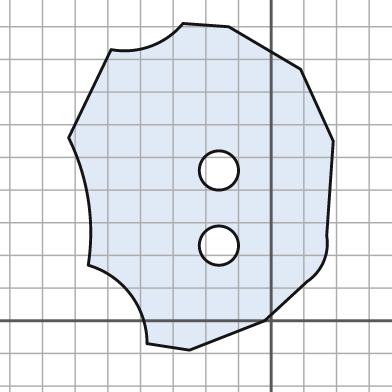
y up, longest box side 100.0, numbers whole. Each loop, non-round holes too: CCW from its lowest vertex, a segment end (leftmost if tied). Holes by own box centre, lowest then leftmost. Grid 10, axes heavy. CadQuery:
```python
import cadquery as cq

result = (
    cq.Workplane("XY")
    .moveTo(-25.0, -9.0)
    .lineTo(-2.0, 0.0)
    .lineTo(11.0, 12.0)
    .threePointArc((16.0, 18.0), (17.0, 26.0))
    .lineTo(19.0, 55.0)
    .lineTo(9.0, 77.0)
    .lineTo(-13.0, 90.0)
    .lineTo(-27.0, 91.0)
    .threePointArc((-37.0, 84.0), (-49.0, 83.0))
    .lineTo(-62.0, 56.0)
    .threePointArc((-56.0, 37.0), (-56.0, 17.0))
    .threePointArc((-43.0, 8.0), (-38.0, -7.0))
    .close()
    .moveTo(-16.0, 23.0)
    .circle(6.0)
    .moveTo(-16.0, 46.0)
    .circle(6.0)
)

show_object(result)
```